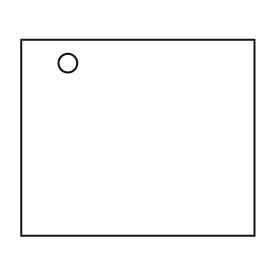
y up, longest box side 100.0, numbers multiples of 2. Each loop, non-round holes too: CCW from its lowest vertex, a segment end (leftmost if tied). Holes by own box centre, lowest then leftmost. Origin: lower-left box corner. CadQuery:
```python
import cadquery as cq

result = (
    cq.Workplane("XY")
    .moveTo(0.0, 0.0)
    .lineTo(100.0, 0.0)
    .lineTo(100.0, 84.0)
    .lineTo(0.0, 84.0)
    .close()
    .moveTo(20.0, 74.0)
    .circle(4.0)
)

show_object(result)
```